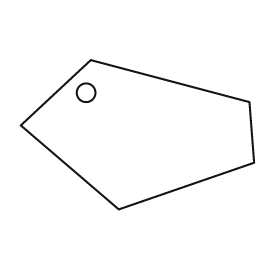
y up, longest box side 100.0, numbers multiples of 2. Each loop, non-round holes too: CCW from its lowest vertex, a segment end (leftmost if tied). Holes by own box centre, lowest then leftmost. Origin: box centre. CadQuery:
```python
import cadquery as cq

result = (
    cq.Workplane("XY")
    .moveTo(-8.0, -32.0)
    .lineTo(50.0, -12.0)
    .lineTo(48.0, 14.0)
    .lineTo(-20.0, 32.0)
    .lineTo(-50.0, 4.0)
    .close()
    .moveTo(-22.0, 18.0)
    .circle(4.0)
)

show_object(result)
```